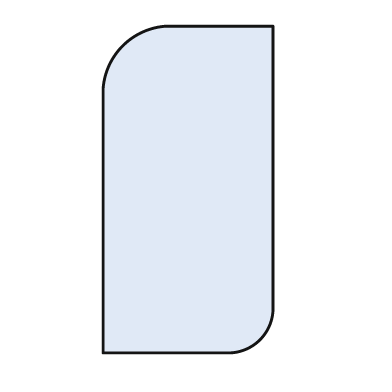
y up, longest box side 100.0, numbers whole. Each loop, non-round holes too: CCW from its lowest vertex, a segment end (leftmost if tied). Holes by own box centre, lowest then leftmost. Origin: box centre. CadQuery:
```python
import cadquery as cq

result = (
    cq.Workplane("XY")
    .moveTo(-26.0, -50.0)
    .lineTo(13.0, -50.0)
    .threePointArc((22.0, -46.0), (26.0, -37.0))
    .lineTo(26.0, 50.0)
    .lineTo(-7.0, 50.0)
    .threePointArc((-20.0, 44.0), (-26.0, 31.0))
    .close()
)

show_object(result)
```